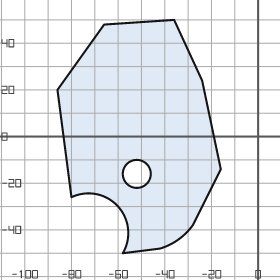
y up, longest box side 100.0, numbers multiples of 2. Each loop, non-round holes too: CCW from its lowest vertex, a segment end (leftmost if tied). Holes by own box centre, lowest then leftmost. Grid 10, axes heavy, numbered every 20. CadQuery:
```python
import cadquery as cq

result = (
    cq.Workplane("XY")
    .moveTo(-58.0, -50.0)
    .lineTo(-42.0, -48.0)
    .threePointArc((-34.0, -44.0), (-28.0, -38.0))
    .lineTo(-16.0, -14.0)
    .lineTo(-24.0, 24.0)
    .lineTo(-36.0, 50.0)
    .lineTo(-66.0, 48.0)
    .lineTo(-86.0, 20.0)
    .lineTo(-80.0, -26.0)
    .threePointArc((-60.0, -30.0), (-58.0, -50.0))
    .close()
    .moveTo(-52.0, -16.0)
    .circle(6.0)
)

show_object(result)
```